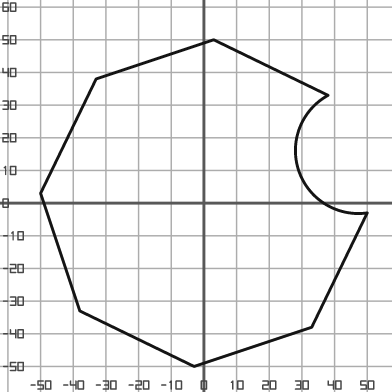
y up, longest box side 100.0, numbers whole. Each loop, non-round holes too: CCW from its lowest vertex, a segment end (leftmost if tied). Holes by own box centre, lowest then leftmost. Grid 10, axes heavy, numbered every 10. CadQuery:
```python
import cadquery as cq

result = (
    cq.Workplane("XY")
    .moveTo(-3.0, -50.0)
    .lineTo(33.0, -38.0)
    .lineTo(50.0, -3.0)
    .threePointArc((29.0, 10.0), (38.0, 33.0))
    .lineTo(3.0, 50.0)
    .lineTo(-33.0, 38.0)
    .lineTo(-50.0, 3.0)
    .lineTo(-38.0, -33.0)
    .close()
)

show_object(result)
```